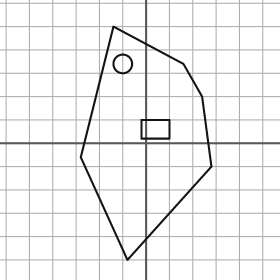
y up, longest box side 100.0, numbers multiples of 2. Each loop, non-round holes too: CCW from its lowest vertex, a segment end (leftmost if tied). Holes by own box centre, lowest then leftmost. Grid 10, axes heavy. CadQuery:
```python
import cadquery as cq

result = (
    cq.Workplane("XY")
    .moveTo(-8.0, -50.0)
    .lineTo(28.0, -10.0)
    .lineTo(24.0, 20.0)
    .lineTo(16.0, 34.0)
    .lineTo(-14.0, 50.0)
    .lineTo(-28.0, -6.0)
    .close()
    .moveTo(-2.0, 2.0)
    .lineTo(10.0, 2.0)
    .lineTo(10.0, 10.0)
    .lineTo(-2.0, 10.0)
    .close()
    .moveTo(-10.0, 34.0)
    .circle(4.0)
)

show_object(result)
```